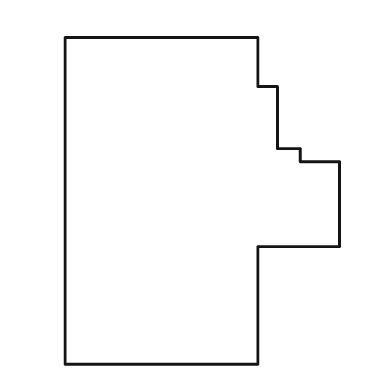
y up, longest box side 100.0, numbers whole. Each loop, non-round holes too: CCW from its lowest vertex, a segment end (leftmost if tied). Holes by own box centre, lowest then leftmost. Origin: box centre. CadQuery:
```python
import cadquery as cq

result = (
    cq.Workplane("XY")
    .moveTo(-42.0, -50.0)
    .lineTo(17.0, -50.0)
    .lineTo(17.0, -14.0)
    .lineTo(42.0, -14.0)
    .lineTo(42.0, 12.0)
    .lineTo(30.0, 12.0)
    .lineTo(30.0, 16.0)
    .lineTo(23.0, 16.0)
    .lineTo(23.0, 35.0)
    .lineTo(17.0, 35.0)
    .lineTo(17.0, 50.0)
    .lineTo(-42.0, 50.0)
    .close()
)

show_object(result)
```